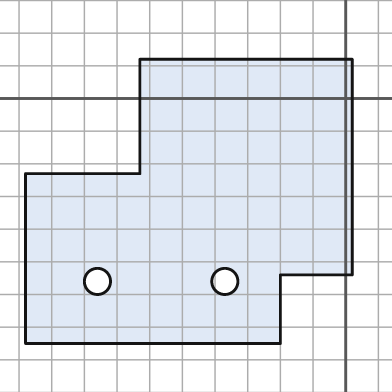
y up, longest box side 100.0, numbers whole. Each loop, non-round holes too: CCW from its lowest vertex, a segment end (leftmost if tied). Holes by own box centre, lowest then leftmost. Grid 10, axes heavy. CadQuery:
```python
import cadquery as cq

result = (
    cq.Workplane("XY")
    .moveTo(-98.0, -75.0)
    .lineTo(-20.0, -75.0)
    .lineTo(-20.0, -54.0)
    .lineTo(2.0, -54.0)
    .lineTo(2.0, 12.0)
    .lineTo(-63.0, 12.0)
    .lineTo(-63.0, -23.0)
    .lineTo(-98.0, -23.0)
    .close()
    .moveTo(-76.0, -56.0)
    .circle(4.0)
    .moveTo(-37.0, -56.0)
    .circle(4.0)
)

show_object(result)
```